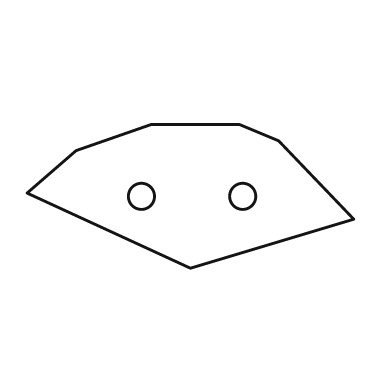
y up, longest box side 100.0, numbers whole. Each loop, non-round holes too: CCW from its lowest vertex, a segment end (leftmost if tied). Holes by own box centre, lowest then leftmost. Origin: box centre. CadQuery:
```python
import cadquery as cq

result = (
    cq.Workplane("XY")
    .moveTo(0.0, -22.0)
    .lineTo(50.0, -7.0)
    .lineTo(27.0, 17.0)
    .lineTo(15.0, 22.0)
    .lineTo(-12.0, 22.0)
    .lineTo(-35.0, 14.0)
    .lineTo(-50.0, 1.0)
    .close()
    .moveTo(-15.0, 0.0)
    .circle(4.0)
    .moveTo(16.0, 0.0)
    .circle(4.0)
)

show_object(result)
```